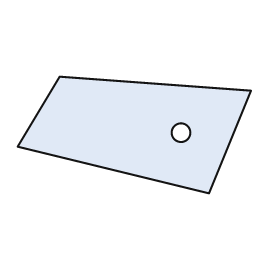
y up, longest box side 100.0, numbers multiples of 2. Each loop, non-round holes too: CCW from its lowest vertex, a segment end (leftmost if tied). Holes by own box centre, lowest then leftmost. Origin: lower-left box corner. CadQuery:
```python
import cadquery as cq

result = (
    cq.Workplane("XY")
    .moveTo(82.0, 0.0)
    .lineTo(100.0, 44.0)
    .lineTo(18.0, 50.0)
    .lineTo(0.0, 20.0)
    .close()
    .moveTo(70.0, 26.0)
    .circle(4.0)
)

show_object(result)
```